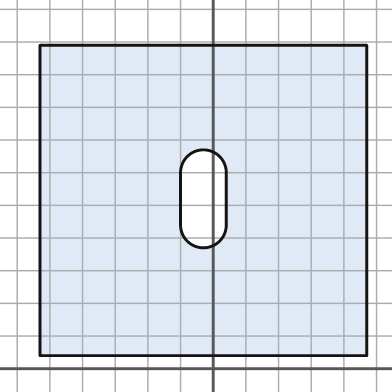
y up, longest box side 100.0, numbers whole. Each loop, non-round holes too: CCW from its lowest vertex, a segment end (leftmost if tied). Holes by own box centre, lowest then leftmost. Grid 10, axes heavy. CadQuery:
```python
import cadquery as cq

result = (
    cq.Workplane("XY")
    .moveTo(-53.0, 4.0)
    .lineTo(47.0, 4.0)
    .lineTo(47.0, 99.0)
    .lineTo(-53.0, 99.0)
    .close()
    .moveTo(-10.0, 44.0)
    .threePointArc((-3.0, 37.0), (4.0, 44.0))
    .lineTo(4.0, 60.0)
    .threePointArc((-3.0, 67.0), (-10.0, 60.0))
    .close()
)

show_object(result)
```